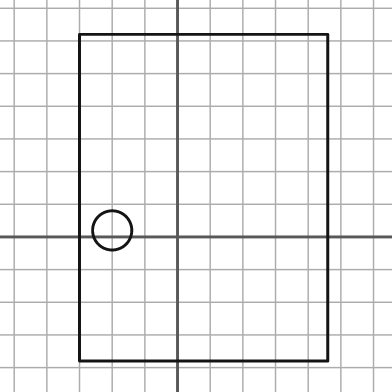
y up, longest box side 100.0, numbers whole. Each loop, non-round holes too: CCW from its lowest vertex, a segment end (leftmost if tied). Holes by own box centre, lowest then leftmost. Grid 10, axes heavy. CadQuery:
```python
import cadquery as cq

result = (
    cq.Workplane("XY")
    .moveTo(-30.0, -38.0)
    .lineTo(46.0, -38.0)
    .lineTo(46.0, 62.0)
    .lineTo(-30.0, 62.0)
    .close()
    .moveTo(-20.0, 2.0)
    .circle(6.0)
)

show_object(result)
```